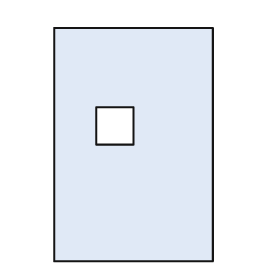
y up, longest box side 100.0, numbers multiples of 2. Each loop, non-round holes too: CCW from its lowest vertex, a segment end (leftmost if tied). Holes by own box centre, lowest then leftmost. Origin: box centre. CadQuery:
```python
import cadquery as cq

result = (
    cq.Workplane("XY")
    .moveTo(-34.0, -50.0)
    .lineTo(34.0, -50.0)
    .lineTo(34.0, 50.0)
    .lineTo(-34.0, 50.0)
    .close()
    .moveTo(-16.0, 0.0)
    .lineTo(0.0, 0.0)
    .lineTo(0.0, 16.0)
    .lineTo(-16.0, 16.0)
    .close()
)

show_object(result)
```